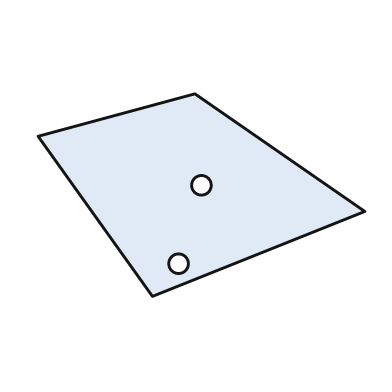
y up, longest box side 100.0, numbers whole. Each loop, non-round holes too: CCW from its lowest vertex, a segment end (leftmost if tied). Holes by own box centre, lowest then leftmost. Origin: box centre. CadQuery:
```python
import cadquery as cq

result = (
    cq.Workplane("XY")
    .moveTo(-15.0, -31.0)
    .lineTo(50.0, -5.0)
    .lineTo(-2.0, 31.0)
    .lineTo(-50.0, 18.0)
    .close()
    .moveTo(-7.0, -21.0)
    .circle(3.0)
    .moveTo(0.0, 3.0)
    .circle(3.0)
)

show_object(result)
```